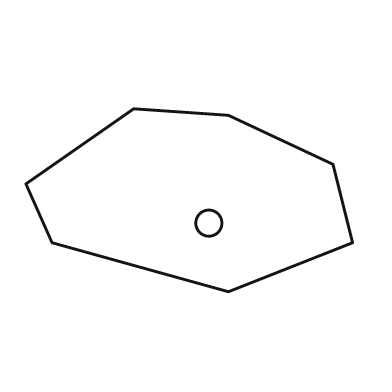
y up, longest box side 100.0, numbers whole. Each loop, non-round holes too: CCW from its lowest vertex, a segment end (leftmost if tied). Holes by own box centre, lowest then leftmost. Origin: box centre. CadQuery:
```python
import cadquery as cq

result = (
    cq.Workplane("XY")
    .moveTo(12.0, -28.0)
    .lineTo(50.0, -13.0)
    .lineTo(44.0, 11.0)
    .lineTo(12.0, 26.0)
    .lineTo(-17.0, 28.0)
    .lineTo(-50.0, 5.0)
    .lineTo(-42.0, -13.0)
    .close()
    .moveTo(6.0, -7.0)
    .circle(4.0)
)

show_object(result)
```